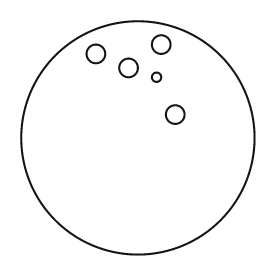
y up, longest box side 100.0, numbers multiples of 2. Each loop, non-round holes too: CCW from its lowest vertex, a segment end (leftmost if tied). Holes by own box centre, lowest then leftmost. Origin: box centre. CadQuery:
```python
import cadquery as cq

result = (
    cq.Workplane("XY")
    .moveTo(0.0, 0.0)
    .circle(50.0)
    .moveTo(16.0, 10.0)
    .circle(4.0)
    .moveTo(8.0, 26.0)
    .circle(2.0)
    .moveTo(-4.0, 30.0)
    .circle(4.0)
    .moveTo(-18.0, 36.0)
    .circle(4.0)
    .moveTo(10.0, 40.0)
    .circle(4.0)
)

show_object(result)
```